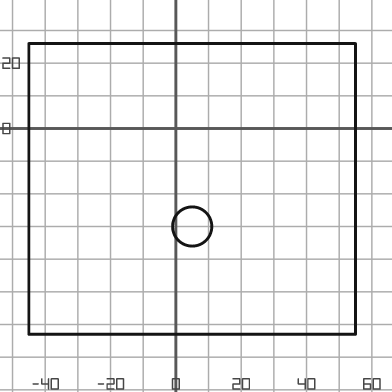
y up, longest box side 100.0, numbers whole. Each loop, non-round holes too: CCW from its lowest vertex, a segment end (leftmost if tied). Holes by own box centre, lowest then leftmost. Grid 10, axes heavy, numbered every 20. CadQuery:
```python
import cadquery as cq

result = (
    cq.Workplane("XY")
    .moveTo(-45.0, -63.0)
    .lineTo(55.0, -63.0)
    .lineTo(55.0, 26.0)
    .lineTo(-45.0, 26.0)
    .close()
    .moveTo(5.0, -30.0)
    .circle(6.0)
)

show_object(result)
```